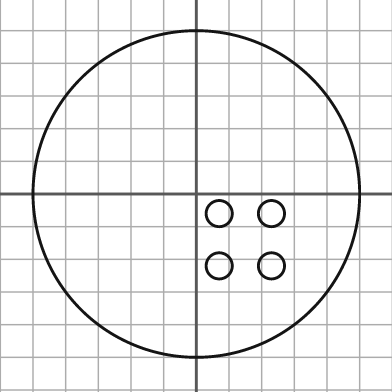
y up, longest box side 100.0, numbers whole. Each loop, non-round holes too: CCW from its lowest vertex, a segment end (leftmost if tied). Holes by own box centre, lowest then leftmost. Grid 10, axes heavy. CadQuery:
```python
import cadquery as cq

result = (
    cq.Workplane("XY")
    .moveTo(0.0, 0.0)
    .circle(50.0)
    .moveTo(7.0, -22.0)
    .circle(4.0)
    .moveTo(23.0, -22.0)
    .circle(4.0)
    .moveTo(7.0, -6.0)
    .circle(4.0)
    .moveTo(23.0, -6.0)
    .circle(4.0)
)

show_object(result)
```